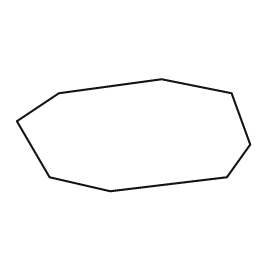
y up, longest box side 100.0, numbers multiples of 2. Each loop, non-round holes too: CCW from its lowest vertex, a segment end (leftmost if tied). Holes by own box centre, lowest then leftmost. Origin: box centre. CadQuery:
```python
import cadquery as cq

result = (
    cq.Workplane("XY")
    .moveTo(-10.0, -24.0)
    .lineTo(40.0, -18.0)
    .lineTo(50.0, -4.0)
    .lineTo(42.0, 18.0)
    .lineTo(12.0, 24.0)
    .lineTo(-32.0, 18.0)
    .lineTo(-50.0, 6.0)
    .lineTo(-36.0, -18.0)
    .close()
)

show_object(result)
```